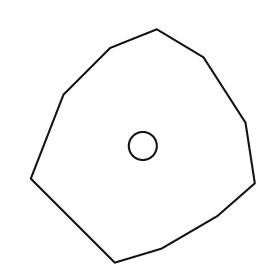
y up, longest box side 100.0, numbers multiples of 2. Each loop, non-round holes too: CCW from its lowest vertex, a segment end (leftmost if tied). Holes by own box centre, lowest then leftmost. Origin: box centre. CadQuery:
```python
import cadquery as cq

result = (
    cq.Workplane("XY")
    .moveTo(-12.0, -50.0)
    .lineTo(8.0, -44.0)
    .lineTo(32.0, -30.0)
    .lineTo(48.0, -16.0)
    .lineTo(44.0, 10.0)
    .lineTo(26.0, 38.0)
    .lineTo(6.0, 50.0)
    .lineTo(-14.0, 42.0)
    .lineTo(-34.0, 22.0)
    .lineTo(-48.0, -14.0)
    .close()
    .moveTo(0.0, 0.0)
    .circle(6.0)
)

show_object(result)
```